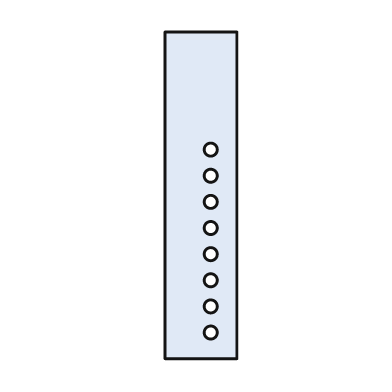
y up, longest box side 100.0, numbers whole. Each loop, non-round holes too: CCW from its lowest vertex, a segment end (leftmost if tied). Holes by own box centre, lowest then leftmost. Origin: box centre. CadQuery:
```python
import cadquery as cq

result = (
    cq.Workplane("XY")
    .moveTo(-11.0, -50.0)
    .lineTo(11.0, -50.0)
    .lineTo(11.0, 50.0)
    .lineTo(-11.0, 50.0)
    .close()
    .moveTo(3.0, -42.0)
    .circle(2.0)
    .moveTo(3.0, -34.0)
    .circle(2.0)
    .moveTo(3.0, -26.0)
    .circle(2.0)
    .moveTo(3.0, -18.0)
    .circle(2.0)
    .moveTo(3.0, -10.0)
    .circle(2.0)
    .moveTo(3.0, -2.0)
    .circle(2.0)
    .moveTo(3.0, 6.0)
    .circle(2.0)
    .moveTo(3.0, 14.0)
    .circle(2.0)
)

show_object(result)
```